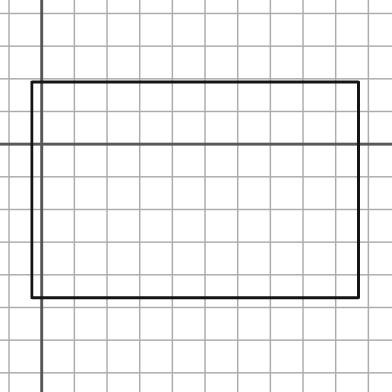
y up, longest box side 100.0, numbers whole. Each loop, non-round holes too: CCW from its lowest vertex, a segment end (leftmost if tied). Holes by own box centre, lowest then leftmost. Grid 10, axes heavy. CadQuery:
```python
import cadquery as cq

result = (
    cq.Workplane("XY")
    .moveTo(-3.0, -47.0)
    .lineTo(97.0, -47.0)
    .lineTo(97.0, 19.0)
    .lineTo(-3.0, 19.0)
    .close()
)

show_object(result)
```